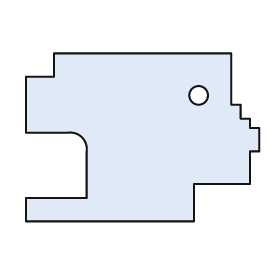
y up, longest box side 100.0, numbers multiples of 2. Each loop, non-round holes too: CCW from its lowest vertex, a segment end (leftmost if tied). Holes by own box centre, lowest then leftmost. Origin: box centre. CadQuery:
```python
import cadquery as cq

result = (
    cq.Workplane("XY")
    .moveTo(-50.0, -36.0)
    .lineTo(22.0, -36.0)
    .lineTo(22.0, -20.0)
    .lineTo(46.0, -20.0)
    .lineTo(46.0, -6.0)
    .lineTo(50.0, -6.0)
    .lineTo(50.0, 4.0)
    .lineTo(46.0, 4.0)
    .lineTo(46.0, 8.0)
    .lineTo(42.0, 8.0)
    .lineTo(42.0, 14.0)
    .lineTo(38.0, 14.0)
    .lineTo(38.0, 36.0)
    .lineTo(-38.0, 36.0)
    .lineTo(-38.0, 26.0)
    .lineTo(-50.0, 26.0)
    .lineTo(-50.0, 2.0)
    .lineTo(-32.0, 2.0)
    .threePointArc((-26.0, 0.0), (-24.0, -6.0))
    .lineTo(-24.0, -26.0)
    .lineTo(-50.0, -26.0)
    .close()
    .moveTo(24.0, 18.0)
    .circle(4.0)
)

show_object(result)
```